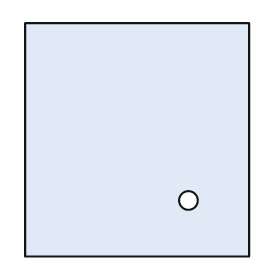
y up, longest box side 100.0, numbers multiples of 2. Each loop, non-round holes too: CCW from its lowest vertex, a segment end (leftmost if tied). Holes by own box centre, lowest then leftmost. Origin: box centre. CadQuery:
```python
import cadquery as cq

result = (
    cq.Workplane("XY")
    .moveTo(-48.0, -50.0)
    .lineTo(48.0, -50.0)
    .lineTo(48.0, 50.0)
    .lineTo(-48.0, 50.0)
    .close()
    .moveTo(22.0, -26.0)
    .circle(4.0)
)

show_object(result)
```